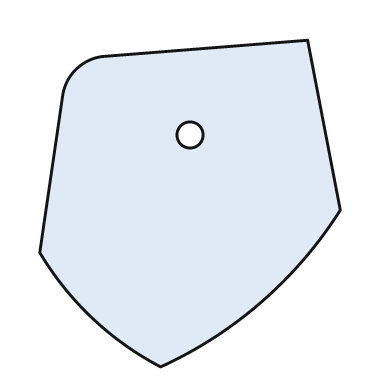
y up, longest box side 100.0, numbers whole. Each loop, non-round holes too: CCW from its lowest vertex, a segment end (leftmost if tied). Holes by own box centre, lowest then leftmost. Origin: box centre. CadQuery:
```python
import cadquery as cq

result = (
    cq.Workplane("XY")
    .moveTo(-9.0, -50.0)
    .threePointArc((22.0, -30.0), (46.0, -2.0))
    .lineTo(36.0, 50.0)
    .lineTo(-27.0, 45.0)
    .threePointArc((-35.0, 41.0), (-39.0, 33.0))
    .lineTo(-46.0, -15.0)
    .threePointArc((-30.0, -35.0), (-9.0, -50.0))
    .close()
    .moveTo(0.0, 21.0)
    .circle(4.0)
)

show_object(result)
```